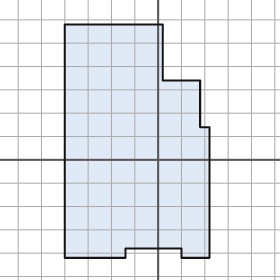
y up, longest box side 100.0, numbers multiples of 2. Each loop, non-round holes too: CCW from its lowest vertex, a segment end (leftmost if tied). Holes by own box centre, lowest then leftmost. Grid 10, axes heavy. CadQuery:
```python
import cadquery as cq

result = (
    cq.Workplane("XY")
    .moveTo(-40.0, -42.0)
    .lineTo(-14.0, -42.0)
    .lineTo(-14.0, -38.0)
    .lineTo(10.0, -38.0)
    .lineTo(10.0, -42.0)
    .lineTo(22.0, -42.0)
    .lineTo(22.0, 14.0)
    .lineTo(18.0, 14.0)
    .lineTo(18.0, 34.0)
    .lineTo(2.0, 34.0)
    .lineTo(2.0, 58.0)
    .lineTo(-40.0, 58.0)
    .close()
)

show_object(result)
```